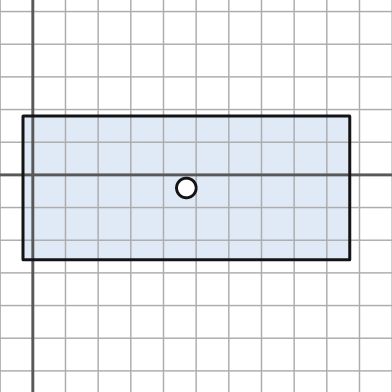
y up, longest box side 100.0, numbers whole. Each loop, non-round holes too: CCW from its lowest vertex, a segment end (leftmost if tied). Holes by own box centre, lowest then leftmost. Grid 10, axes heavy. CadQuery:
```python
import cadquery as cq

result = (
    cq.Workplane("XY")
    .moveTo(-3.0, -26.0)
    .lineTo(97.0, -26.0)
    .lineTo(97.0, 18.0)
    .lineTo(-3.0, 18.0)
    .close()
    .moveTo(47.0, -4.0)
    .circle(3.0)
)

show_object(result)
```